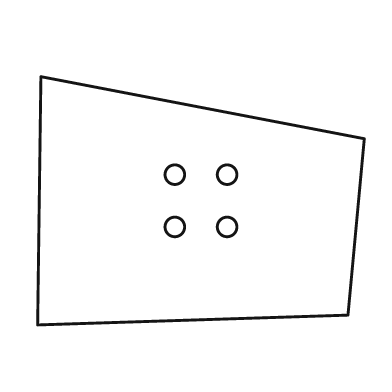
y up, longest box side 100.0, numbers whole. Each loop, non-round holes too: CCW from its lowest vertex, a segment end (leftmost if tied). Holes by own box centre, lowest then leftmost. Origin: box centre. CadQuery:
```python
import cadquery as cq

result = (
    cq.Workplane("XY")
    .moveTo(-50.0, -38.0)
    .lineTo(45.0, -35.0)
    .lineTo(50.0, 19.0)
    .lineTo(-49.0, 38.0)
    .close()
    .moveTo(-8.0, -8.0)
    .circle(3.0)
    .moveTo(8.0, -8.0)
    .circle(3.0)
    .moveTo(-8.0, 8.0)
    .circle(3.0)
    .moveTo(8.0, 8.0)
    .circle(3.0)
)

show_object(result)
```